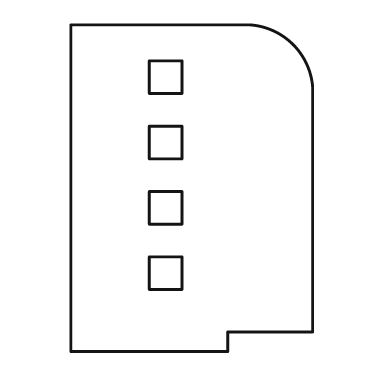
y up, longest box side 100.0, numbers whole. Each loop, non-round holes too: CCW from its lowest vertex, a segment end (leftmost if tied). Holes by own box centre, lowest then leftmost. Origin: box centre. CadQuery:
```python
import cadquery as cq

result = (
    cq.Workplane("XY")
    .moveTo(-37.0, -50.0)
    .lineTo(11.0, -50.0)
    .lineTo(11.0, -44.0)
    .lineTo(37.0, -44.0)
    .lineTo(37.0, 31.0)
    .threePointArc((31.0, 44.0), (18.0, 50.0))
    .lineTo(-37.0, 50.0)
    .close()
    .moveTo(-13.0, -31.0)
    .lineTo(-3.0, -31.0)
    .lineTo(-3.0, -21.0)
    .lineTo(-13.0, -21.0)
    .close()
    .moveTo(-13.0, -11.0)
    .lineTo(-3.0, -11.0)
    .lineTo(-3.0, -1.0)
    .lineTo(-13.0, -1.0)
    .close()
    .moveTo(-13.0, 9.0)
    .lineTo(-3.0, 9.0)
    .lineTo(-3.0, 19.0)
    .lineTo(-13.0, 19.0)
    .close()
    .moveTo(-13.0, 29.0)
    .lineTo(-3.0, 29.0)
    .lineTo(-3.0, 39.0)
    .lineTo(-13.0, 39.0)
    .close()
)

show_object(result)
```